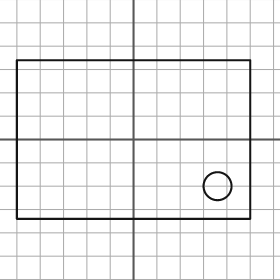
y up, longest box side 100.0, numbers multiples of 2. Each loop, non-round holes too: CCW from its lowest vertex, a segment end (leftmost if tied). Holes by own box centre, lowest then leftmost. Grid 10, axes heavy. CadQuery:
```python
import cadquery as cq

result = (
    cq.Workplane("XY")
    .moveTo(-50.0, -34.0)
    .lineTo(50.0, -34.0)
    .lineTo(50.0, 34.0)
    .lineTo(-50.0, 34.0)
    .close()
    .moveTo(36.0, -20.0)
    .circle(6.0)
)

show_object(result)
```